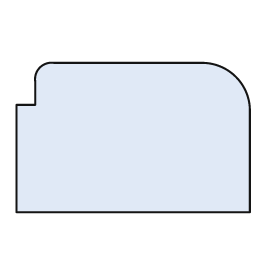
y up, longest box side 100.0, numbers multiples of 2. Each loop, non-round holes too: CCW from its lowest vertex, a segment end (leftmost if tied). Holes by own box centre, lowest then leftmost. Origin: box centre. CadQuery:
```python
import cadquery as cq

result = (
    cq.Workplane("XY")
    .moveTo(-50.0, -32.0)
    .lineTo(50.0, -32.0)
    .lineTo(50.0, 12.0)
    .threePointArc((44.0, 26.0), (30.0, 32.0))
    .lineTo(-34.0, 32.0)
    .threePointArc((-40.0, 30.0), (-42.0, 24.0))
    .lineTo(-42.0, 14.0)
    .lineTo(-50.0, 14.0)
    .close()
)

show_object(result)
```